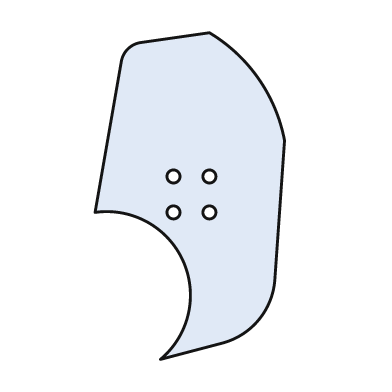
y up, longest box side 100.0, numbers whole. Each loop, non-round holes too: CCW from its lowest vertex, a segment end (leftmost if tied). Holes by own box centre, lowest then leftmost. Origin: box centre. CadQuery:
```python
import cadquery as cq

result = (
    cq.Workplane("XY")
    .moveTo(-9.0, -50.0)
    .lineTo(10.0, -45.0)
    .threePointArc((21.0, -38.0), (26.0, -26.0))
    .lineTo(29.0, 17.0)
    .threePointArc((21.0, 36.0), (6.0, 50.0))
    .lineTo(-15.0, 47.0)
    .threePointArc((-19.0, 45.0), (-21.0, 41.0))
    .lineTo(-29.0, -5.0)
    .threePointArc((-2.0, -20.0), (-9.0, -50.0))
    .close()
    .moveTo(-5.0, -5.0)
    .circle(2.0)
    .moveTo(6.0, -5.0)
    .circle(2.0)
    .moveTo(-5.0, 6.0)
    .circle(2.0)
    .moveTo(6.0, 6.0)
    .circle(2.0)
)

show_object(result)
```